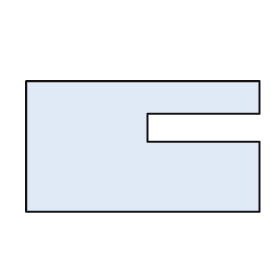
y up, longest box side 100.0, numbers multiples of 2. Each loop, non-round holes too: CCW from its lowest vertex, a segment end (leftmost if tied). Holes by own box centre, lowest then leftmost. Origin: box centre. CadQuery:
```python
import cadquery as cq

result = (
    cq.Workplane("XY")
    .moveTo(-50.0, -28.0)
    .lineTo(50.0, -28.0)
    .lineTo(50.0, 2.0)
    .lineTo(2.0, 2.0)
    .lineTo(2.0, 14.0)
    .lineTo(50.0, 14.0)
    .lineTo(50.0, 28.0)
    .lineTo(-50.0, 28.0)
    .close()
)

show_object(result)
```